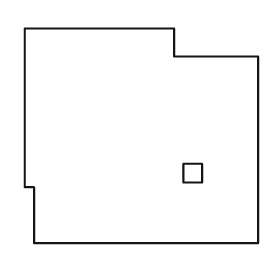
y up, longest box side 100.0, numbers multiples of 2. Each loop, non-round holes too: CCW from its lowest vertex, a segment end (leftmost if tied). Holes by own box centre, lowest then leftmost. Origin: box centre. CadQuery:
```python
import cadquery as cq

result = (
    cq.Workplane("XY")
    .moveTo(-46.0, -46.0)
    .lineTo(50.0, -46.0)
    .lineTo(50.0, 34.0)
    .lineTo(14.0, 34.0)
    .lineTo(14.0, 46.0)
    .lineTo(-50.0, 46.0)
    .lineTo(-50.0, -22.0)
    .lineTo(-46.0, -22.0)
    .close()
    .moveTo(18.0, -20.0)
    .lineTo(26.0, -20.0)
    .lineTo(26.0, -12.0)
    .lineTo(18.0, -12.0)
    .close()
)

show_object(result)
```